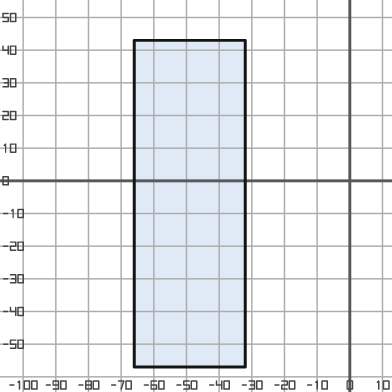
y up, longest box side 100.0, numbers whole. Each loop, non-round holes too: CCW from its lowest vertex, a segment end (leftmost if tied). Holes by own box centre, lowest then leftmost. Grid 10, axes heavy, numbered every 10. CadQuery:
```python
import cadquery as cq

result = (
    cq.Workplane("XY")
    .moveTo(-66.0, -57.0)
    .lineTo(-32.0, -57.0)
    .lineTo(-32.0, 43.0)
    .lineTo(-66.0, 43.0)
    .close()
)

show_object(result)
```